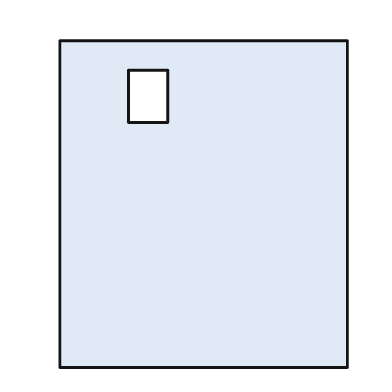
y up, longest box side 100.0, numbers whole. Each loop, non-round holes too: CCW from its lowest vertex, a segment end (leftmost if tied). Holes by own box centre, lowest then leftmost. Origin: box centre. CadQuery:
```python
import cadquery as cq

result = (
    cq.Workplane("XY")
    .moveTo(-44.0, -50.0)
    .lineTo(44.0, -50.0)
    .lineTo(44.0, 50.0)
    .lineTo(-44.0, 50.0)
    .close()
    .moveTo(-23.0, 25.0)
    .lineTo(-11.0, 25.0)
    .lineTo(-11.0, 41.0)
    .lineTo(-23.0, 41.0)
    .close()
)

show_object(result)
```